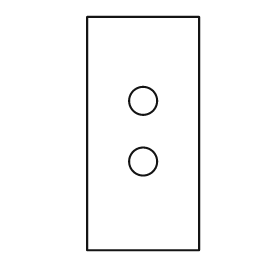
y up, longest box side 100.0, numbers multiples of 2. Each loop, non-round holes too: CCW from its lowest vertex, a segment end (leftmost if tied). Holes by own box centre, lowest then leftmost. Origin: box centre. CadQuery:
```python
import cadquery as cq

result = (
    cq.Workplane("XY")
    .moveTo(-24.0, -50.0)
    .lineTo(24.0, -50.0)
    .lineTo(24.0, 50.0)
    .lineTo(-24.0, 50.0)
    .close()
    .moveTo(0.0, -12.0)
    .circle(6.0)
    .moveTo(0.0, 14.0)
    .circle(6.0)
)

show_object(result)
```